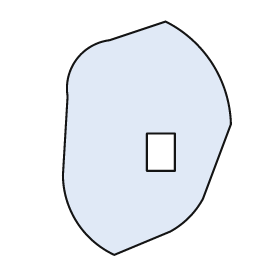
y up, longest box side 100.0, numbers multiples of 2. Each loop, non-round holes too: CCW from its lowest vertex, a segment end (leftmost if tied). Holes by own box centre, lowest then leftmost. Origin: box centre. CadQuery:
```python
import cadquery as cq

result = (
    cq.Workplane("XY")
    .moveTo(-14.0, -50.0)
    .lineTo(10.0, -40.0)
    .threePointArc((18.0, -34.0), (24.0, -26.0))
    .lineTo(36.0, 6.0)
    .threePointArc((28.0, 32.0), (8.0, 50.0))
    .lineTo(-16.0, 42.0)
    .threePointArc((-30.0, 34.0), (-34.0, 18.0))
    .lineTo(-36.0, -16.0)
    .threePointArc((-30.0, -36.0), (-14.0, -50.0))
    .close()
    .moveTo(0.0, -14.0)
    .lineTo(12.0, -14.0)
    .lineTo(12.0, 2.0)
    .lineTo(0.0, 2.0)
    .close()
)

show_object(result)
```